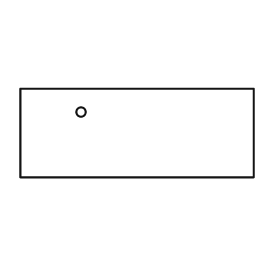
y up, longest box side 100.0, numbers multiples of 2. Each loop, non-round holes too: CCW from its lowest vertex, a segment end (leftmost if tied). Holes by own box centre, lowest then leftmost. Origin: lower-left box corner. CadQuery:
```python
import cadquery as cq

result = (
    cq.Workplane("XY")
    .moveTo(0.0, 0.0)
    .lineTo(100.0, 0.0)
    .lineTo(100.0, 38.0)
    .lineTo(0.0, 38.0)
    .close()
    .moveTo(26.0, 28.0)
    .circle(2.0)
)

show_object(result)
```